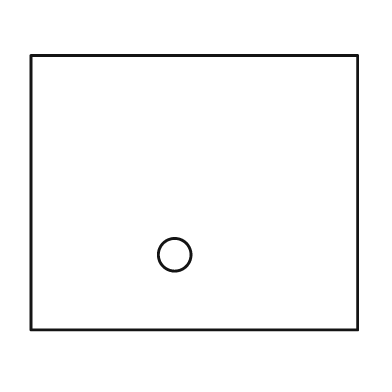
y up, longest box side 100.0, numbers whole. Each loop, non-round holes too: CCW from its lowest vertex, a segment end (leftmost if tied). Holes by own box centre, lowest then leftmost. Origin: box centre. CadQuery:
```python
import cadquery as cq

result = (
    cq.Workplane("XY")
    .moveTo(-50.0, -42.0)
    .lineTo(50.0, -42.0)
    .lineTo(50.0, 42.0)
    .lineTo(-50.0, 42.0)
    .close()
    .moveTo(-6.0, -19.0)
    .circle(5.0)
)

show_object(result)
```